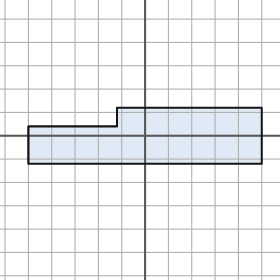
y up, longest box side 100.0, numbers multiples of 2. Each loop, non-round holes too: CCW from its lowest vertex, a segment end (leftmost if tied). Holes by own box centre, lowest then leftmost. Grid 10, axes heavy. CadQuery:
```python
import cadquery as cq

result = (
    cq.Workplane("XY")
    .moveTo(-50.0, -12.0)
    .lineTo(50.0, -12.0)
    .lineTo(50.0, 12.0)
    .lineTo(-12.0, 12.0)
    .lineTo(-12.0, 4.0)
    .lineTo(-50.0, 4.0)
    .close()
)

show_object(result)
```